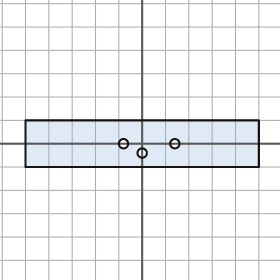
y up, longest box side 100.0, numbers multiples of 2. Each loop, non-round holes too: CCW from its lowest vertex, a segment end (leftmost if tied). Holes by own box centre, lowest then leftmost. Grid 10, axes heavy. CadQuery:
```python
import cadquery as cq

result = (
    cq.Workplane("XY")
    .moveTo(-50.0, -10.0)
    .lineTo(50.0, -10.0)
    .lineTo(50.0, 10.0)
    .lineTo(-50.0, 10.0)
    .close()
    .moveTo(0.0, -4.0)
    .circle(2.0)
    .moveTo(-8.0, 0.0)
    .circle(2.0)
    .moveTo(14.0, 0.0)
    .circle(2.0)
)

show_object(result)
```